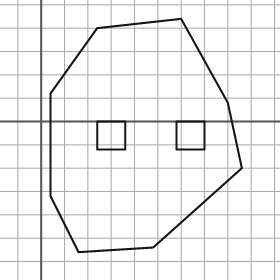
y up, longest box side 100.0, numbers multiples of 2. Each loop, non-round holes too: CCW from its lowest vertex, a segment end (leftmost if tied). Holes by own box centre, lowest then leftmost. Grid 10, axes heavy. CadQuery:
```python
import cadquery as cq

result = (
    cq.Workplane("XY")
    .moveTo(16.0, -56.0)
    .lineTo(48.0, -54.0)
    .lineTo(86.0, -20.0)
    .lineTo(80.0, 8.0)
    .lineTo(60.0, 44.0)
    .lineTo(24.0, 40.0)
    .lineTo(4.0, 12.0)
    .lineTo(4.0, -32.0)
    .close()
    .moveTo(24.0, -12.0)
    .lineTo(36.0, -12.0)
    .lineTo(36.0, 0.0)
    .lineTo(24.0, 0.0)
    .close()
    .moveTo(58.0, -12.0)
    .lineTo(70.0, -12.0)
    .lineTo(70.0, 0.0)
    .lineTo(58.0, 0.0)
    .close()
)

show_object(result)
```